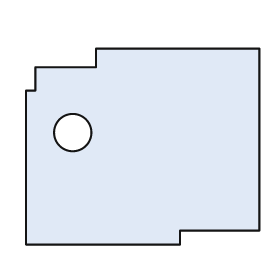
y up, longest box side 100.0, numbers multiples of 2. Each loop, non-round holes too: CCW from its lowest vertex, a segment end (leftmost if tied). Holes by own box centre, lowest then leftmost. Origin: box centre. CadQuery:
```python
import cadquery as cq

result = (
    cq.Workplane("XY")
    .moveTo(-50.0, -42.0)
    .lineTo(16.0, -42.0)
    .lineTo(16.0, -36.0)
    .lineTo(50.0, -36.0)
    .lineTo(50.0, 42.0)
    .lineTo(-20.0, 42.0)
    .lineTo(-20.0, 34.0)
    .lineTo(-46.0, 34.0)
    .lineTo(-46.0, 24.0)
    .lineTo(-50.0, 24.0)
    .close()
    .moveTo(-30.0, 6.0)
    .circle(8.0)
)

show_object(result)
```